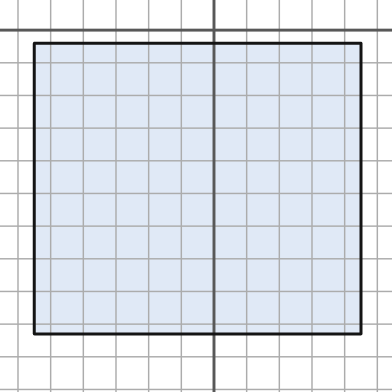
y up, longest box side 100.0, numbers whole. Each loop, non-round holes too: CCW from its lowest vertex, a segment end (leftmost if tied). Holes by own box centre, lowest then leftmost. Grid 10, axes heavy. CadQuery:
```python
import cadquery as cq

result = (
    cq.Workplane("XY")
    .moveTo(-55.0, -93.0)
    .lineTo(45.0, -93.0)
    .lineTo(45.0, -4.0)
    .lineTo(-55.0, -4.0)
    .close()
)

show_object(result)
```